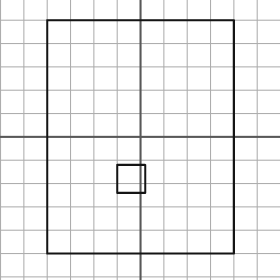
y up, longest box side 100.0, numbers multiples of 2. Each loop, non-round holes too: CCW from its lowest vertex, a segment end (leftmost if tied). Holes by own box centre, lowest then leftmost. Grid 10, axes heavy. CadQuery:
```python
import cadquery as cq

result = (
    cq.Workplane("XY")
    .moveTo(-40.0, -50.0)
    .lineTo(40.0, -50.0)
    .lineTo(40.0, 50.0)
    .lineTo(-40.0, 50.0)
    .close()
    .moveTo(-10.0, -24.0)
    .lineTo(2.0, -24.0)
    .lineTo(2.0, -12.0)
    .lineTo(-10.0, -12.0)
    .close()
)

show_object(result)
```